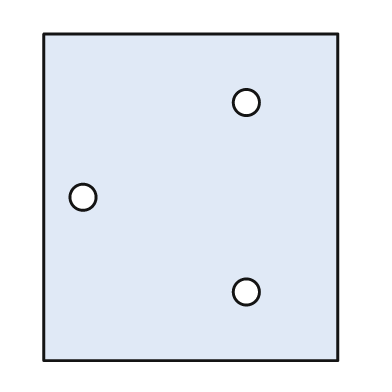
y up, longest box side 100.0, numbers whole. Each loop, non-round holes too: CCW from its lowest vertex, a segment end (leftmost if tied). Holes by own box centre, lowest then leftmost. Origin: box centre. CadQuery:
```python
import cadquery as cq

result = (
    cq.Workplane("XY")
    .moveTo(-45.0, -50.0)
    .lineTo(45.0, -50.0)
    .lineTo(45.0, 50.0)
    .lineTo(-45.0, 50.0)
    .close()
    .moveTo(17.0, -29.0)
    .circle(4.0)
    .moveTo(-33.0, 0.0)
    .circle(4.0)
    .moveTo(17.0, 29.0)
    .circle(4.0)
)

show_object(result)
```